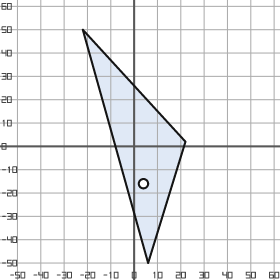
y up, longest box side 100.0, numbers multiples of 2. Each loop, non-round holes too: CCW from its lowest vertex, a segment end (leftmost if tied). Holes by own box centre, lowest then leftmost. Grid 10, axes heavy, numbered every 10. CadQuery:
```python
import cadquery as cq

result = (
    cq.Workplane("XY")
    .moveTo(6.0, -50.0)
    .lineTo(22.0, 2.0)
    .lineTo(-22.0, 50.0)
    .close()
    .moveTo(4.0, -16.0)
    .circle(2.0)
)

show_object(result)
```